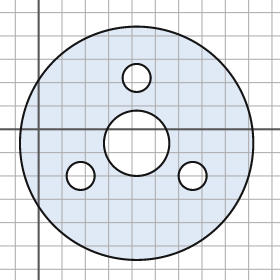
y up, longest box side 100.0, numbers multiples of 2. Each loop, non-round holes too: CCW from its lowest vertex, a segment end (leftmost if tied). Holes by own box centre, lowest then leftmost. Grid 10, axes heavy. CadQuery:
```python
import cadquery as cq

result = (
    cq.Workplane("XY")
    .moveTo(42.0, -6.0)
    .circle(50.0)
    .moveTo(18.0, -20.0)
    .circle(6.0)
    .moveTo(66.0, -20.0)
    .circle(6.0)
    .moveTo(42.0, -6.0)
    .circle(14.0)
    .moveTo(42.0, 22.0)
    .circle(6.0)
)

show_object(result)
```